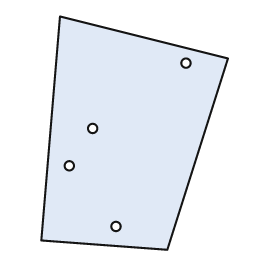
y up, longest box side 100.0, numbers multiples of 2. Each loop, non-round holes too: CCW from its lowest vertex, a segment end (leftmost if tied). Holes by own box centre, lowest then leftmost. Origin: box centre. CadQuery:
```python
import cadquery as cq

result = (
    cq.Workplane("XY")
    .moveTo(14.0, -50.0)
    .lineTo(40.0, 32.0)
    .lineTo(-32.0, 50.0)
    .lineTo(-40.0, -46.0)
    .close()
    .moveTo(-8.0, -40.0)
    .circle(2.0)
    .moveTo(-28.0, -14.0)
    .circle(2.0)
    .moveTo(-18.0, 2.0)
    .circle(2.0)
    .moveTo(22.0, 30.0)
    .circle(2.0)
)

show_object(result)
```